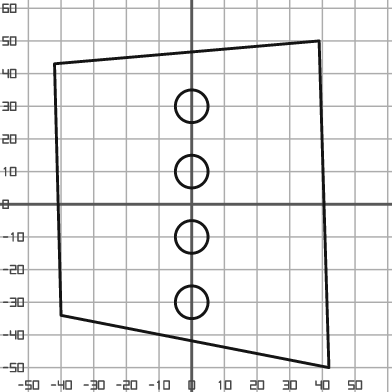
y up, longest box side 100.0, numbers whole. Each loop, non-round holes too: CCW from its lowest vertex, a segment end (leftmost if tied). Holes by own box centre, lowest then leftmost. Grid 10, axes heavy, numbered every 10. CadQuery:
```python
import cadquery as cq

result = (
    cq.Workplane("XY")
    .moveTo(42.0, -50.0)
    .lineTo(39.0, 50.0)
    .lineTo(-42.0, 43.0)
    .lineTo(-40.0, -34.0)
    .close()
    .moveTo(0.0, -30.0)
    .circle(5.0)
    .moveTo(0.0, -10.0)
    .circle(5.0)
    .moveTo(0.0, 10.0)
    .circle(5.0)
    .moveTo(0.0, 30.0)
    .circle(5.0)
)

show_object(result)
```